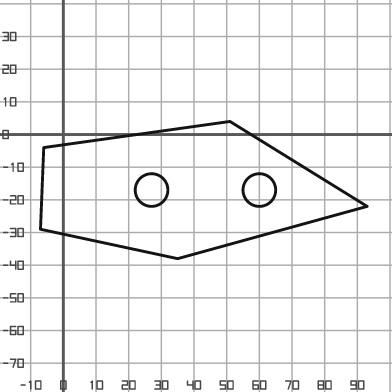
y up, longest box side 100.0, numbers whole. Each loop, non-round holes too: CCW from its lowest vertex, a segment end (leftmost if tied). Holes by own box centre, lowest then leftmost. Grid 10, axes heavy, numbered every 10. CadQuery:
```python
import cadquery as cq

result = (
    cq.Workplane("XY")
    .moveTo(35.0, -38.0)
    .lineTo(93.0, -22.0)
    .lineTo(51.0, 4.0)
    .lineTo(-6.0, -4.0)
    .lineTo(-7.0, -29.0)
    .close()
    .moveTo(27.0, -17.0)
    .circle(5.0)
    .moveTo(60.0, -17.0)
    .circle(5.0)
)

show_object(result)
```